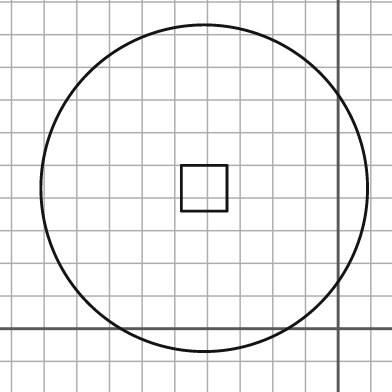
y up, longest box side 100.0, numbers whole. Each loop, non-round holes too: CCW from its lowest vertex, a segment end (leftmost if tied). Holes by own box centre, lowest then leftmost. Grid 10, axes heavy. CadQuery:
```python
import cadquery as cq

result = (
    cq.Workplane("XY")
    .moveTo(-41.0, 43.0)
    .circle(50.0)
    .moveTo(-48.0, 36.0)
    .lineTo(-34.0, 36.0)
    .lineTo(-34.0, 50.0)
    .lineTo(-48.0, 50.0)
    .close()
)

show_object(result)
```